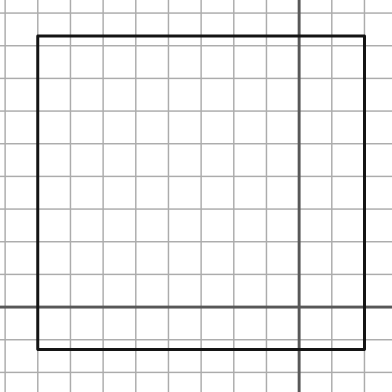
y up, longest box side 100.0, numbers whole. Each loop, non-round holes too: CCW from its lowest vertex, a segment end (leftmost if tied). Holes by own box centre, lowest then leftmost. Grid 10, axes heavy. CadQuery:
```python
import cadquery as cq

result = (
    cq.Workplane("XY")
    .moveTo(-80.0, -13.0)
    .lineTo(20.0, -13.0)
    .lineTo(20.0, 83.0)
    .lineTo(-80.0, 83.0)
    .close()
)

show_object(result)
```